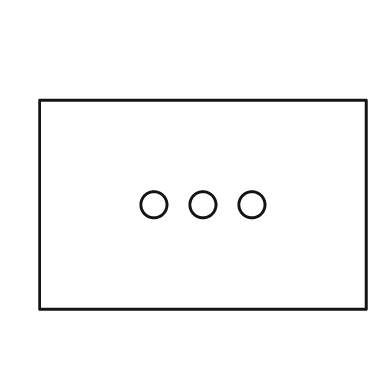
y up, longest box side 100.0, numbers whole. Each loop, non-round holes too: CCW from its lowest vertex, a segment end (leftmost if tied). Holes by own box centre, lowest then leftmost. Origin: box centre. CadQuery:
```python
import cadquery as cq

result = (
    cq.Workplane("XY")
    .moveTo(-50.0, -32.0)
    .lineTo(50.0, -32.0)
    .lineTo(50.0, 32.0)
    .lineTo(-50.0, 32.0)
    .close()
    .moveTo(-15.0, 0.0)
    .circle(4.0)
    .moveTo(0.0, 0.0)
    .circle(4.0)
    .moveTo(15.0, 0.0)
    .circle(4.0)
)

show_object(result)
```